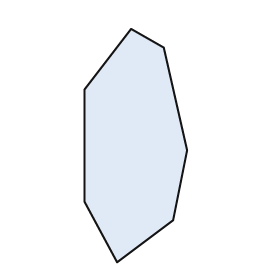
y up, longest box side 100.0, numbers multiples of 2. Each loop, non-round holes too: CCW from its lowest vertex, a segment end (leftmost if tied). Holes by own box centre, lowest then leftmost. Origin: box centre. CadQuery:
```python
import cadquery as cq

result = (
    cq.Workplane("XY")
    .moveTo(-8.0, -50.0)
    .lineTo(16.0, -32.0)
    .lineTo(22.0, -2.0)
    .lineTo(12.0, 42.0)
    .lineTo(-2.0, 50.0)
    .lineTo(-22.0, 24.0)
    .lineTo(-22.0, -24.0)
    .close()
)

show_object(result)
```